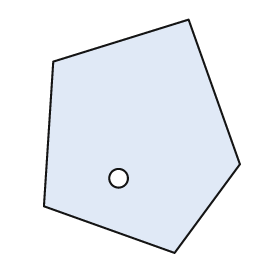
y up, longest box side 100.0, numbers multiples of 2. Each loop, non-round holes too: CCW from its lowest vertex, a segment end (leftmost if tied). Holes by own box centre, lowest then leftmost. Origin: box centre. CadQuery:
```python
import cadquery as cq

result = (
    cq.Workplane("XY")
    .moveTo(14.0, -50.0)
    .lineTo(42.0, -12.0)
    .lineTo(20.0, 50.0)
    .lineTo(-38.0, 32.0)
    .lineTo(-42.0, -30.0)
    .close()
    .moveTo(-10.0, -18.0)
    .circle(4.0)
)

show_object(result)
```